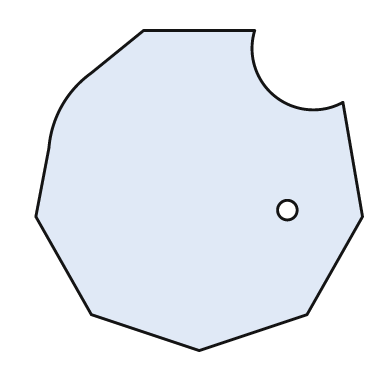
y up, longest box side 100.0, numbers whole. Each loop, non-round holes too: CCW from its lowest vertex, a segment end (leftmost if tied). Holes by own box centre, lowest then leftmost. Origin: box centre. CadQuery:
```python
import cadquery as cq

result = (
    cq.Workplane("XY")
    .moveTo(0.0, -49.0)
    .lineTo(33.0, -38.0)
    .lineTo(50.0, -8.0)
    .lineTo(44.0, 27.0)
    .threePointArc((23.0, 29.0), (17.0, 49.0))
    .lineTo(-17.0, 49.0)
    .lineTo(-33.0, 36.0)
    .threePointArc((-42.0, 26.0), (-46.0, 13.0))
    .lineTo(-50.0, -8.0)
    .lineTo(-33.0, -38.0)
    .close()
    .moveTo(27.0, -6.0)
    .circle(3.0)
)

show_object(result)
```